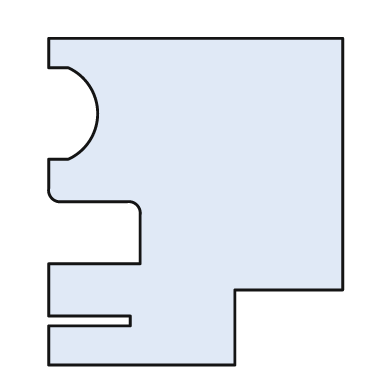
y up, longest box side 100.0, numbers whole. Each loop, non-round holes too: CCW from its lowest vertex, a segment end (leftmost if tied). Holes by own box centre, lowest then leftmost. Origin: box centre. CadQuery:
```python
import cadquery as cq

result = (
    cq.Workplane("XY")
    .moveTo(-45.0, -50.0)
    .lineTo(12.0, -50.0)
    .lineTo(12.0, -27.0)
    .lineTo(45.0, -27.0)
    .lineTo(45.0, 50.0)
    .lineTo(-45.0, 50.0)
    .lineTo(-45.0, 41.0)
    .lineTo(-39.0, 41.0)
    .threePointArc((-30.0, 27.0), (-39.0, 13.0))
    .lineTo(-45.0, 13.0)
    .lineTo(-45.0, 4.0)
    .threePointArc((-44.0, 1.0), (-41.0, 0.0))
    .lineTo(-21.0, 0.0)
    .threePointArc((-18.0, -1.0), (-17.0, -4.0))
    .lineTo(-17.0, -19.0)
    .lineTo(-45.0, -19.0)
    .lineTo(-45.0, -35.0)
    .lineTo(-20.0, -35.0)
    .lineTo(-20.0, -38.0)
    .lineTo(-45.0, -38.0)
    .close()
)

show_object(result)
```